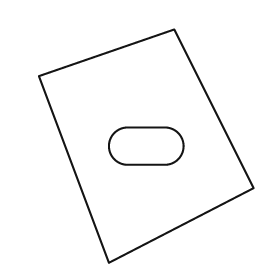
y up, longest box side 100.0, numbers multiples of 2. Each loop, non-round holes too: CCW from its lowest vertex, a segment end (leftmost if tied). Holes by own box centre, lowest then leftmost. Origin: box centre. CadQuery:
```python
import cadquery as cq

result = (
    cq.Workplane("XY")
    .moveTo(-16.0, -50.0)
    .lineTo(46.0, -18.0)
    .lineTo(12.0, 50.0)
    .lineTo(-46.0, 30.0)
    .close()
    .moveTo(-8.0, -8.0)
    .lineTo(8.0, -8.0)
    .threePointArc((16.0, 0.0), (8.0, 8.0))
    .lineTo(-8.0, 8.0)
    .threePointArc((-16.0, 0.0), (-8.0, -8.0))
    .close()
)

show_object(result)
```